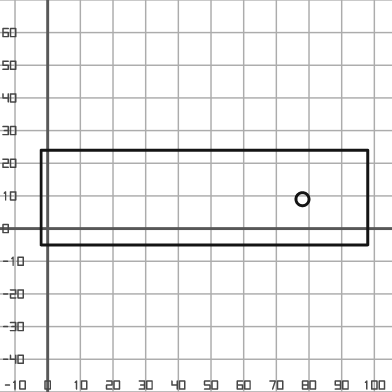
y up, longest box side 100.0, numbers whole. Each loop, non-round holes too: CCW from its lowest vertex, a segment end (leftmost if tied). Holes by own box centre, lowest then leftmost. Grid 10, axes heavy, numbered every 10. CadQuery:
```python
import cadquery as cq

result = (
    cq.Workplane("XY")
    .moveTo(-2.0, -5.0)
    .lineTo(98.0, -5.0)
    .lineTo(98.0, 24.0)
    .lineTo(-2.0, 24.0)
    .close()
    .moveTo(78.0, 9.0)
    .circle(2.0)
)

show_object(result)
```